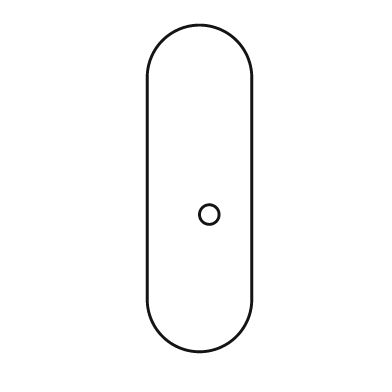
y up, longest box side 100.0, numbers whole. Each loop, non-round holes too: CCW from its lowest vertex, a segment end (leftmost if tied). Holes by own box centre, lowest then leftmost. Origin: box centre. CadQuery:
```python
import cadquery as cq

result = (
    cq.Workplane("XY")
    .moveTo(-16.0, -34.0)
    .threePointArc((0.0, -50.0), (16.0, -34.0))
    .lineTo(16.0, 34.0)
    .threePointArc((0.0, 50.0), (-16.0, 34.0))
    .close()
    .moveTo(3.0, -8.0)
    .circle(3.0)
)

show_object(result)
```